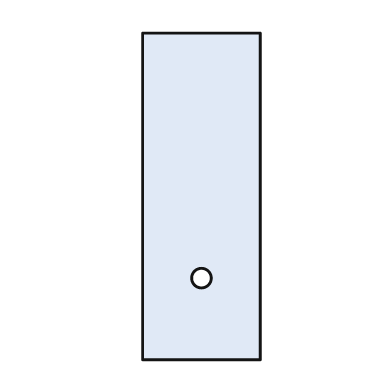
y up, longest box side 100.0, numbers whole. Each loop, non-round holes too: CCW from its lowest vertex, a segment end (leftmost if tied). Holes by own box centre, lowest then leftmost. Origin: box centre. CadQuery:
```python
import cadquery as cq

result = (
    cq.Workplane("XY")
    .moveTo(-18.0, -50.0)
    .lineTo(18.0, -50.0)
    .lineTo(18.0, 50.0)
    .lineTo(-18.0, 50.0)
    .close()
    .moveTo(0.0, -25.0)
    .circle(3.0)
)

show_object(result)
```